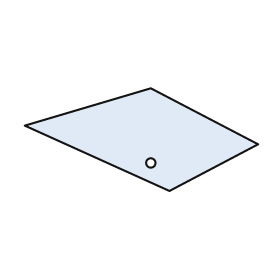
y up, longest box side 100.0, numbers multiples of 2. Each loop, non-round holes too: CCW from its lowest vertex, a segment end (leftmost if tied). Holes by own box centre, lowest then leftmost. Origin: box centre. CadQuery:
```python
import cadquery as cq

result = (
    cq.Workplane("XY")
    .moveTo(12.0, -22.0)
    .lineTo(50.0, -2.0)
    .lineTo(4.0, 22.0)
    .lineTo(-50.0, 6.0)
    .close()
    .moveTo(4.0, -10.0)
    .circle(2.0)
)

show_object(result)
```